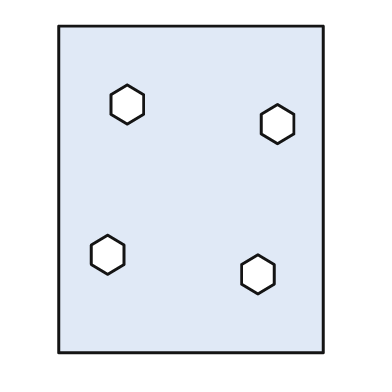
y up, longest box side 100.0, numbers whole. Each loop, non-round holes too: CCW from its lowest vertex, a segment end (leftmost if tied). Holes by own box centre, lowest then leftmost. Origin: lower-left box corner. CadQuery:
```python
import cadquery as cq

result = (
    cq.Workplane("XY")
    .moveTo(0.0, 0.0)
    .lineTo(81.0, 0.0)
    .lineTo(81.0, 100.0)
    .lineTo(0.0, 100.0)
    .close()
    .moveTo(61.0, 18.0)
    .lineTo(66.0, 21.0)
    .lineTo(66.0, 27.0)
    .lineTo(61.0, 30.0)
    .lineTo(56.0, 27.0)
    .lineTo(56.0, 21.0)
    .close()
    .moveTo(15.0, 24.0)
    .lineTo(20.0, 27.0)
    .lineTo(20.0, 33.0)
    .lineTo(15.0, 36.0)
    .lineTo(10.0, 33.0)
    .lineTo(10.0, 27.0)
    .close()
    .moveTo(67.0, 64.0)
    .lineTo(72.0, 67.0)
    .lineTo(72.0, 73.0)
    .lineTo(67.0, 76.0)
    .lineTo(62.0, 73.0)
    .lineTo(62.0, 67.0)
    .close()
    .moveTo(21.0, 70.0)
    .lineTo(26.0, 73.0)
    .lineTo(26.0, 79.0)
    .lineTo(21.0, 82.0)
    .lineTo(16.0, 79.0)
    .lineTo(16.0, 73.0)
    .close()
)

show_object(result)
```